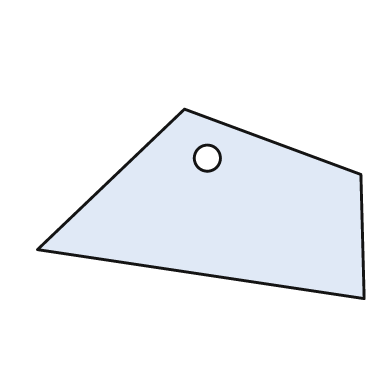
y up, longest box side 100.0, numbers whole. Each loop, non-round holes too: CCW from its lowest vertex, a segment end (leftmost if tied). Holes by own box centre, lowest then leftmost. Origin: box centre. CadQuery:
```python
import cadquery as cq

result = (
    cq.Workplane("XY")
    .moveTo(50.0, -29.0)
    .lineTo(49.0, 9.0)
    .lineTo(-5.0, 29.0)
    .lineTo(-50.0, -14.0)
    .close()
    .moveTo(2.0, 14.0)
    .circle(4.0)
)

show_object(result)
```